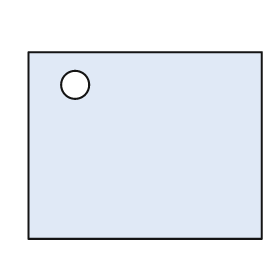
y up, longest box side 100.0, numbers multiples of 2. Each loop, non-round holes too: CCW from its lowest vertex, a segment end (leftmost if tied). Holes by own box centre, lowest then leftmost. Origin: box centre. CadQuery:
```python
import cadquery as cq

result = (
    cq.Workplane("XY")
    .moveTo(-50.0, -40.0)
    .lineTo(50.0, -40.0)
    .lineTo(50.0, 40.0)
    .lineTo(-50.0, 40.0)
    .close()
    .moveTo(-30.0, 26.0)
    .circle(6.0)
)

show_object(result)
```